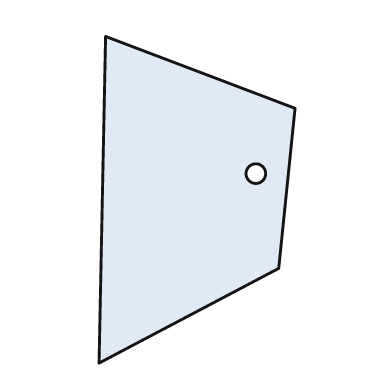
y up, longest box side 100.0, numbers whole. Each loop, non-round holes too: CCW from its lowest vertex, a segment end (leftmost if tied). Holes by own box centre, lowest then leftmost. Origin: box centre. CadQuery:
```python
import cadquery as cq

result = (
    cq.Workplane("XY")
    .moveTo(-30.0, -50.0)
    .lineTo(25.0, -21.0)
    .lineTo(30.0, 28.0)
    .lineTo(-28.0, 50.0)
    .close()
    .moveTo(18.0, 8.0)
    .circle(3.0)
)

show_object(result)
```